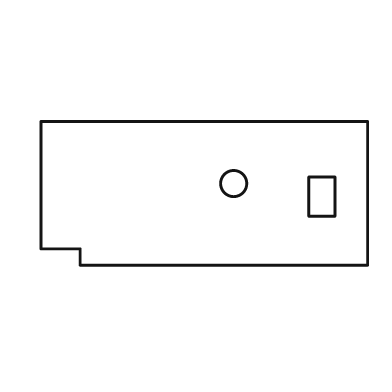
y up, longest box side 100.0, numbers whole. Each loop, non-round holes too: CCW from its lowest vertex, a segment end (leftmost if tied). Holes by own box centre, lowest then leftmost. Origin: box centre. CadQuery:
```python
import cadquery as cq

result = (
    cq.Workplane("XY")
    .moveTo(-38.0, -22.0)
    .lineTo(50.0, -22.0)
    .lineTo(50.0, 22.0)
    .lineTo(-50.0, 22.0)
    .lineTo(-50.0, -17.0)
    .lineTo(-38.0, -17.0)
    .close()
    .moveTo(32.0, -7.0)
    .lineTo(40.0, -7.0)
    .lineTo(40.0, 5.0)
    .lineTo(32.0, 5.0)
    .close()
    .moveTo(9.0, 3.0)
    .circle(4.0)
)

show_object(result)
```